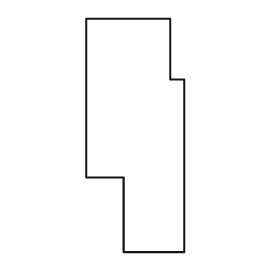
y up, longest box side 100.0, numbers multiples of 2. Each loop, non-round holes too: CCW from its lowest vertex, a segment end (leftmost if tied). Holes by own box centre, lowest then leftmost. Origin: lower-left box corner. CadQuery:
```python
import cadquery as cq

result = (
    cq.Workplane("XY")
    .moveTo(16.0, 0.0)
    .lineTo(42.0, 0.0)
    .lineTo(42.0, 74.0)
    .lineTo(36.0, 74.0)
    .lineTo(36.0, 100.0)
    .lineTo(0.0, 100.0)
    .lineTo(0.0, 32.0)
    .lineTo(16.0, 32.0)
    .close()
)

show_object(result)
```